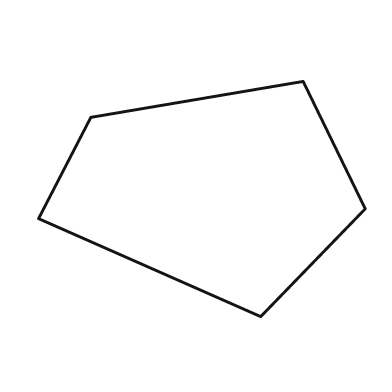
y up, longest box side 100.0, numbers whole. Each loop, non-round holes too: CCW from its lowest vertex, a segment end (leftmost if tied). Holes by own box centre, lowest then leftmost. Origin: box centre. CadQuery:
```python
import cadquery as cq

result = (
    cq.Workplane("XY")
    .moveTo(18.0, -36.0)
    .lineTo(50.0, -3.0)
    .lineTo(31.0, 36.0)
    .lineTo(-34.0, 25.0)
    .lineTo(-50.0, -6.0)
    .close()
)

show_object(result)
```